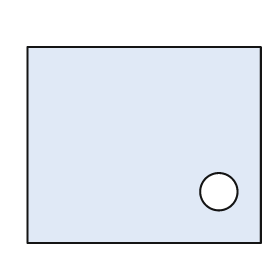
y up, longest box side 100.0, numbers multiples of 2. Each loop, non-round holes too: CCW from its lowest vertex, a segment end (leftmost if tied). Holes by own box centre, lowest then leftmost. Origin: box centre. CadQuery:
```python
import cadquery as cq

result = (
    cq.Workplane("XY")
    .moveTo(-50.0, -42.0)
    .lineTo(50.0, -42.0)
    .lineTo(50.0, 42.0)
    .lineTo(-50.0, 42.0)
    .close()
    .moveTo(32.0, -20.0)
    .circle(8.0)
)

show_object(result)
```